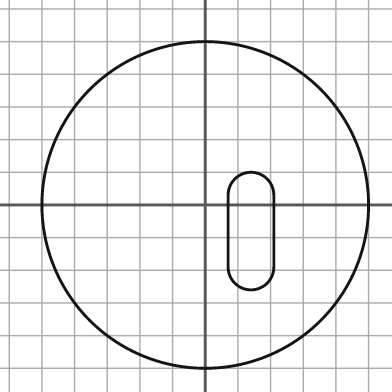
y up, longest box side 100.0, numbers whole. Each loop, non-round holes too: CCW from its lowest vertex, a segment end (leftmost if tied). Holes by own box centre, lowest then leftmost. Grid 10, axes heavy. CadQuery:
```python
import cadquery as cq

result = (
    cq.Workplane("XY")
    .moveTo(0.0, 0.0)
    .circle(50.0)
    .moveTo(7.0, -19.0)
    .threePointArc((14.0, -26.0), (21.0, -19.0))
    .lineTo(21.0, 3.0)
    .threePointArc((14.0, 10.0), (7.0, 3.0))
    .close()
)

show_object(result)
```